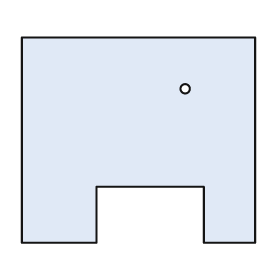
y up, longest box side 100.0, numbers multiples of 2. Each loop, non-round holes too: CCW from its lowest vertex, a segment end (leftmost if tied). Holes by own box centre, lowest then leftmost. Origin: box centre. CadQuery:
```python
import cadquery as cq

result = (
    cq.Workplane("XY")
    .moveTo(-50.0, -44.0)
    .lineTo(-18.0, -44.0)
    .lineTo(-18.0, -20.0)
    .lineTo(28.0, -20.0)
    .lineTo(28.0, -44.0)
    .lineTo(50.0, -44.0)
    .lineTo(50.0, 44.0)
    .lineTo(-50.0, 44.0)
    .close()
    .moveTo(20.0, 22.0)
    .circle(2.0)
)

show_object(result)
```